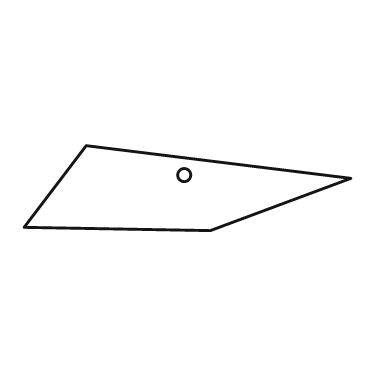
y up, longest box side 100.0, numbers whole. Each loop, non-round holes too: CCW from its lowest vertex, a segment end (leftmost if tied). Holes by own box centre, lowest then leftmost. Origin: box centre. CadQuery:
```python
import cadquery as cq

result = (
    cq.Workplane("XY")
    .moveTo(7.0, -13.0)
    .lineTo(50.0, 3.0)
    .lineTo(-31.0, 13.0)
    .lineTo(-50.0, -12.0)
    .close()
    .moveTo(-1.0, 4.0)
    .circle(2.0)
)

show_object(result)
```